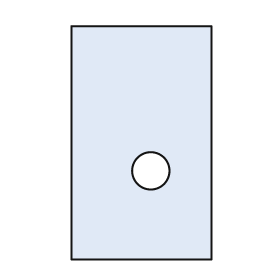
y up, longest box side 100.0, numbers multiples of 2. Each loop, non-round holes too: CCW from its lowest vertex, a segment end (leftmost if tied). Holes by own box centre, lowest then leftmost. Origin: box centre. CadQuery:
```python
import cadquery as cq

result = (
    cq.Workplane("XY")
    .moveTo(-30.0, -50.0)
    .lineTo(30.0, -50.0)
    .lineTo(30.0, 50.0)
    .lineTo(-30.0, 50.0)
    .close()
    .moveTo(4.0, -12.0)
    .circle(8.0)
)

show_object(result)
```